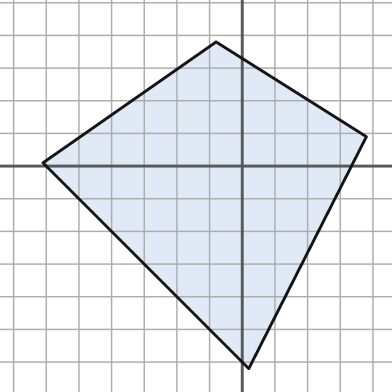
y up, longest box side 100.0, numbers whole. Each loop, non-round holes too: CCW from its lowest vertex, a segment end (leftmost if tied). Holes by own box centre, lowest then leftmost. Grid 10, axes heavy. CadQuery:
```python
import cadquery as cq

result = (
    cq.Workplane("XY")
    .moveTo(2.0, -62.0)
    .lineTo(38.0, 9.0)
    .lineTo(-8.0, 38.0)
    .lineTo(-61.0, 1.0)
    .close()
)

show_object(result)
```